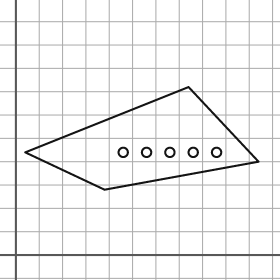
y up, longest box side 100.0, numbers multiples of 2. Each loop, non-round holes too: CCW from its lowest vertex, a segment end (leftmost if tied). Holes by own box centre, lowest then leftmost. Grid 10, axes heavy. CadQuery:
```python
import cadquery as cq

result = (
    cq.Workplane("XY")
    .moveTo(38.0, 28.0)
    .lineTo(104.0, 40.0)
    .lineTo(74.0, 72.0)
    .lineTo(4.0, 44.0)
    .close()
    .moveTo(46.0, 44.0)
    .circle(2.0)
    .moveTo(56.0, 44.0)
    .circle(2.0)
    .moveTo(66.0, 44.0)
    .circle(2.0)
    .moveTo(76.0, 44.0)
    .circle(2.0)
    .moveTo(86.0, 44.0)
    .circle(2.0)
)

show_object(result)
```